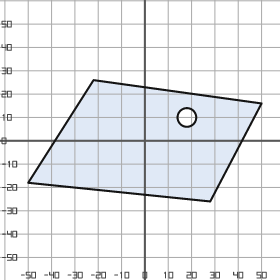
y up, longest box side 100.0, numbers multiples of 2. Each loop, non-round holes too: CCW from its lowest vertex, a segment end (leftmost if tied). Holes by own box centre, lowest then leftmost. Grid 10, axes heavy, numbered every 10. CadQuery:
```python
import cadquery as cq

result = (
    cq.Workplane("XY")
    .moveTo(28.0, -26.0)
    .lineTo(50.0, 16.0)
    .lineTo(-22.0, 26.0)
    .lineTo(-50.0, -18.0)
    .close()
    .moveTo(18.0, 10.0)
    .circle(4.0)
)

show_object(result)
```